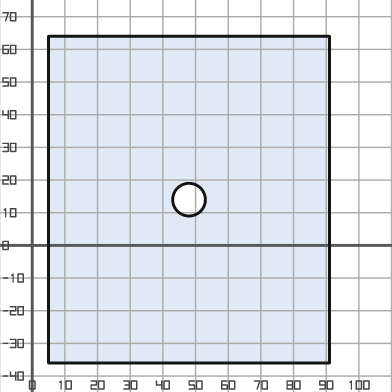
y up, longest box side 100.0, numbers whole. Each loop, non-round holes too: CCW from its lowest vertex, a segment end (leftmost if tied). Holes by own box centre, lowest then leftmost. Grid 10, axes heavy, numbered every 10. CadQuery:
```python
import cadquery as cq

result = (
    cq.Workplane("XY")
    .moveTo(5.0, -36.0)
    .lineTo(91.0, -36.0)
    .lineTo(91.0, 64.0)
    .lineTo(5.0, 64.0)
    .close()
    .moveTo(48.0, 14.0)
    .circle(5.0)
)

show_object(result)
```